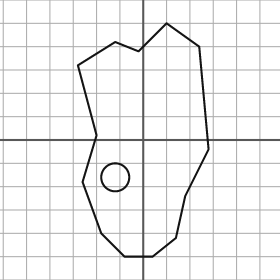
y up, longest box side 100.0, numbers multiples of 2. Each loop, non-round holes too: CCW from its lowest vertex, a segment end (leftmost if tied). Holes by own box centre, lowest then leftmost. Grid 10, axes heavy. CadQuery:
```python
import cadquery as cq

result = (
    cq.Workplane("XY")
    .moveTo(-8.0, -50.0)
    .lineTo(4.0, -50.0)
    .lineTo(14.0, -42.0)
    .lineTo(18.0, -24.0)
    .lineTo(28.0, -4.0)
    .lineTo(24.0, 40.0)
    .lineTo(10.0, 50.0)
    .lineTo(-2.0, 38.0)
    .lineTo(-12.0, 42.0)
    .lineTo(-28.0, 32.0)
    .lineTo(-20.0, 2.0)
    .lineTo(-26.0, -18.0)
    .lineTo(-18.0, -40.0)
    .close()
    .moveTo(-12.0, -16.0)
    .circle(6.0)
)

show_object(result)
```